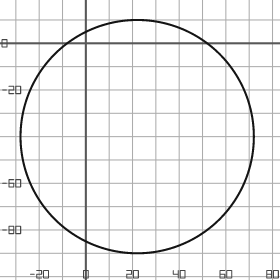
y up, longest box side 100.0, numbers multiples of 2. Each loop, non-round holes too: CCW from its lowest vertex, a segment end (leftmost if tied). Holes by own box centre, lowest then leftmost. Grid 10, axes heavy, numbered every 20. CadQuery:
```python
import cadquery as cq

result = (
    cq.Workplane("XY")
    .moveTo(22.0, -40.0)
    .circle(50.0)
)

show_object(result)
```